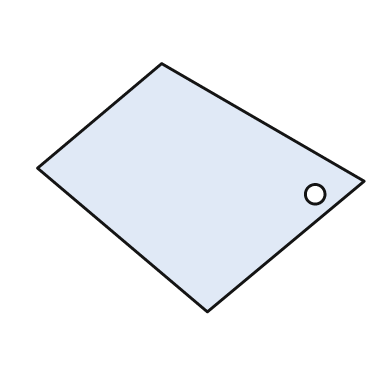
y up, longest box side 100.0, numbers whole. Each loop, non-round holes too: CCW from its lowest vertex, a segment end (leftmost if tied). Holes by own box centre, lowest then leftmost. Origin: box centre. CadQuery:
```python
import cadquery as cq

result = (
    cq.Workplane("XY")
    .moveTo(2.0, -38.0)
    .lineTo(50.0, 2.0)
    .lineTo(-12.0, 38.0)
    .lineTo(-50.0, 6.0)
    .close()
    .moveTo(35.0, -2.0)
    .circle(3.0)
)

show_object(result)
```